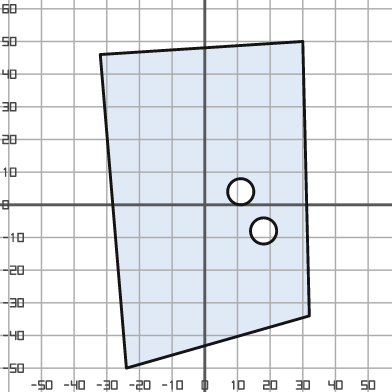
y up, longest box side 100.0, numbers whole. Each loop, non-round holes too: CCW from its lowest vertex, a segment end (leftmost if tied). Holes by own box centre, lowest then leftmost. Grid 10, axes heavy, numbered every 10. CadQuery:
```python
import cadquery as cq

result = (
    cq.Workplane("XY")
    .moveTo(-24.0, -50.0)
    .lineTo(32.0, -34.0)
    .lineTo(30.0, 50.0)
    .lineTo(-32.0, 46.0)
    .close()
    .moveTo(18.0, -8.0)
    .circle(4.0)
    .moveTo(11.0, 4.0)
    .circle(4.0)
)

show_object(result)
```